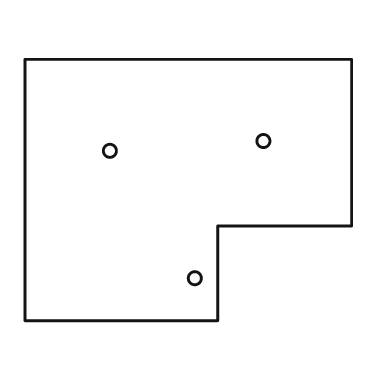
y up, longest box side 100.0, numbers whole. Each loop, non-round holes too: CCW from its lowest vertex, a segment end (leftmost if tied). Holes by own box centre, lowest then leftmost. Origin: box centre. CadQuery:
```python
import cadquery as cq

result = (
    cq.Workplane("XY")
    .moveTo(-50.0, -40.0)
    .lineTo(9.0, -40.0)
    .lineTo(9.0, -11.0)
    .lineTo(50.0, -11.0)
    .lineTo(50.0, 40.0)
    .lineTo(-50.0, 40.0)
    .close()
    .moveTo(2.0, -27.0)
    .circle(2.0)
    .moveTo(-24.0, 12.0)
    .circle(2.0)
    .moveTo(23.0, 15.0)
    .circle(2.0)
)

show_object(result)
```